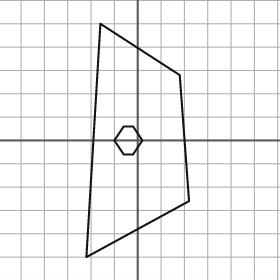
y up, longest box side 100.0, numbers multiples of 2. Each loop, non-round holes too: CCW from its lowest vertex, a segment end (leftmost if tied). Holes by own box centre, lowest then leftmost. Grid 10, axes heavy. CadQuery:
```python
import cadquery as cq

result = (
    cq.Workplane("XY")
    .moveTo(-22.0, -50.0)
    .lineTo(22.0, -26.0)
    .lineTo(18.0, 28.0)
    .lineTo(-16.0, 50.0)
    .close()
    .moveTo(-6.0, -6.0)
    .lineTo(-2.0, -6.0)
    .lineTo(2.0, 0.0)
    .lineTo(-2.0, 6.0)
    .lineTo(-6.0, 6.0)
    .lineTo(-10.0, 0.0)
    .close()
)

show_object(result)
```